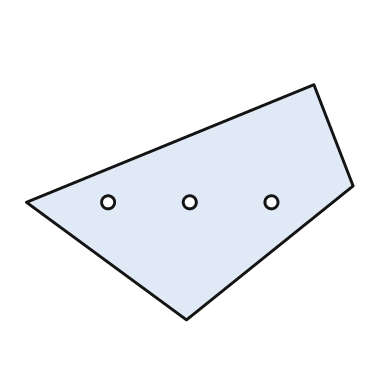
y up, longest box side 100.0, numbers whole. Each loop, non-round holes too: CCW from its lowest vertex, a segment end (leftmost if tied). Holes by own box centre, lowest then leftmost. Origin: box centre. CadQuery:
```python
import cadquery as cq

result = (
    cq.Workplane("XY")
    .moveTo(-1.0, -36.0)
    .lineTo(50.0, 5.0)
    .lineTo(38.0, 36.0)
    .lineTo(-50.0, 0.0)
    .close()
    .moveTo(-25.0, 0.0)
    .circle(2.0)
    .moveTo(0.0, 0.0)
    .circle(2.0)
    .moveTo(25.0, 0.0)
    .circle(2.0)
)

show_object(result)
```